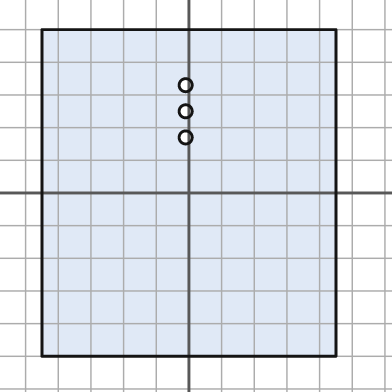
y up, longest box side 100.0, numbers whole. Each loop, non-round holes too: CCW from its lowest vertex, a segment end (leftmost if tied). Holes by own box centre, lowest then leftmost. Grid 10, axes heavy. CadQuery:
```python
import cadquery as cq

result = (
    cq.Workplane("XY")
    .moveTo(-45.0, -50.0)
    .lineTo(45.0, -50.0)
    .lineTo(45.0, 50.0)
    .lineTo(-45.0, 50.0)
    .close()
    .moveTo(-1.0, 17.0)
    .circle(2.0)
    .moveTo(-1.0, 25.0)
    .circle(2.0)
    .moveTo(-1.0, 33.0)
    .circle(2.0)
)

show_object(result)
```